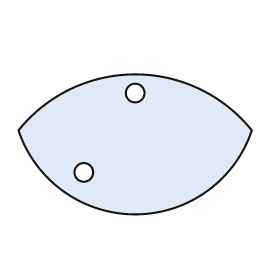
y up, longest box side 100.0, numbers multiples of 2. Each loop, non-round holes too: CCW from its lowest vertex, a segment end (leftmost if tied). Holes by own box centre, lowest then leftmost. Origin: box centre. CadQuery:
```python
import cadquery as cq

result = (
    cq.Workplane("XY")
    .moveTo(-50.0, 6.0)
    .threePointArc((0.0, -30.0), (50.0, 6.0))
    .threePointArc((0.0, 30.0), (-50.0, 6.0))
    .close()
    .moveTo(-22.0, -12.0)
    .circle(4.0)
    .moveTo(0.0, 22.0)
    .circle(4.0)
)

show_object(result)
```